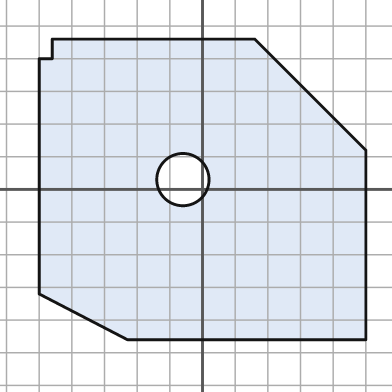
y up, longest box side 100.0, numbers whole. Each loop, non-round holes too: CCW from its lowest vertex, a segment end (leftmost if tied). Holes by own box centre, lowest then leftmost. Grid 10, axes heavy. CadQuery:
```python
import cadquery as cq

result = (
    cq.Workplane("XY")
    .moveTo(-23.0, -46.0)
    .lineTo(50.0, -46.0)
    .lineTo(50.0, 12.0)
    .lineTo(16.0, 46.0)
    .lineTo(-46.0, 46.0)
    .lineTo(-46.0, 40.0)
    .lineTo(-50.0, 40.0)
    .lineTo(-50.0, -32.0)
    .close()
    .moveTo(-6.0, 3.0)
    .circle(8.0)
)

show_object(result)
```